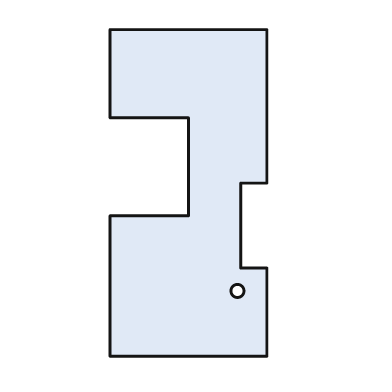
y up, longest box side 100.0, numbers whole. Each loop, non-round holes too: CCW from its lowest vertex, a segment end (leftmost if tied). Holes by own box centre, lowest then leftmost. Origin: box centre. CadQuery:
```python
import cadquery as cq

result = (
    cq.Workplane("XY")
    .moveTo(-24.0, -50.0)
    .lineTo(24.0, -50.0)
    .lineTo(24.0, -23.0)
    .lineTo(16.0, -23.0)
    .lineTo(16.0, 3.0)
    .lineTo(24.0, 3.0)
    .lineTo(24.0, 50.0)
    .lineTo(-24.0, 50.0)
    .lineTo(-24.0, 23.0)
    .lineTo(0.0, 23.0)
    .lineTo(0.0, -7.0)
    .lineTo(-24.0, -7.0)
    .close()
    .moveTo(15.0, -30.0)
    .circle(2.0)
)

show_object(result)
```